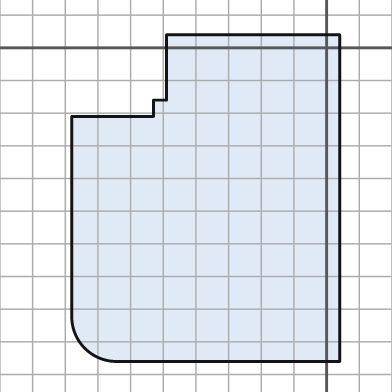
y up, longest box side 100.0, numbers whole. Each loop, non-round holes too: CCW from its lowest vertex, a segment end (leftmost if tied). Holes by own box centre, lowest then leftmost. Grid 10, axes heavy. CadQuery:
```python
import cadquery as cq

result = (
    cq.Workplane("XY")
    .moveTo(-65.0, -96.0)
    .lineTo(4.0, -96.0)
    .lineTo(4.0, 4.0)
    .lineTo(-49.0, 4.0)
    .lineTo(-49.0, -16.0)
    .lineTo(-53.0, -16.0)
    .lineTo(-53.0, -21.0)
    .lineTo(-78.0, -21.0)
    .lineTo(-78.0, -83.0)
    .threePointArc((-74.0, -92.0), (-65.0, -96.0))
    .close()
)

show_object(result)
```